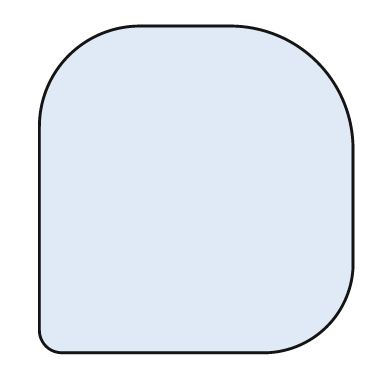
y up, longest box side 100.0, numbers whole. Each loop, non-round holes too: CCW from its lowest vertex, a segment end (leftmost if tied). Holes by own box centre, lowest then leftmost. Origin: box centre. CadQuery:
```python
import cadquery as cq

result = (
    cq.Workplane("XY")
    .moveTo(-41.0, -50.0)
    .lineTo(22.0, -50.0)
    .threePointArc((40.0, -42.0), (48.0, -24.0))
    .lineTo(48.0, 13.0)
    .threePointArc((37.0, 39.0), (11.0, 50.0))
    .lineTo(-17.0, 50.0)
    .threePointArc((-39.0, 41.0), (-48.0, 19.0))
    .lineTo(-48.0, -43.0)
    .threePointArc((-46.0, -48.0), (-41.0, -50.0))
    .close()
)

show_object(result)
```